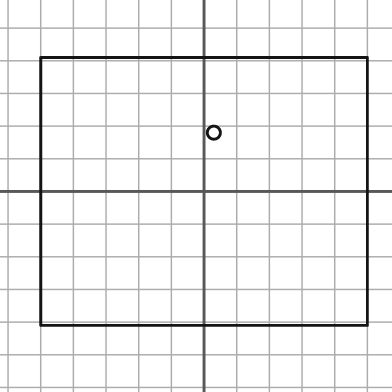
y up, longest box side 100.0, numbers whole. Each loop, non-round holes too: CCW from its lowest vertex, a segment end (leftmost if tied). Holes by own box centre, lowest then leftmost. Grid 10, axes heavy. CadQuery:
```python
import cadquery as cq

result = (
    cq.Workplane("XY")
    .moveTo(-50.0, -41.0)
    .lineTo(50.0, -41.0)
    .lineTo(50.0, 41.0)
    .lineTo(-50.0, 41.0)
    .close()
    .moveTo(3.0, 18.0)
    .circle(2.0)
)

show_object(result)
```